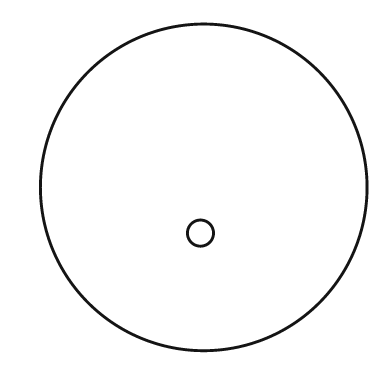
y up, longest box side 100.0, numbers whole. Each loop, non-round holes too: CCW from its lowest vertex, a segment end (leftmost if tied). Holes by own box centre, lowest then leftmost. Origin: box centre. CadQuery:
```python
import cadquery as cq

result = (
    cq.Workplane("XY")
    .moveTo(0.0, 0.0)
    .circle(50.0)
    .moveTo(-1.0, -14.0)
    .circle(4.0)
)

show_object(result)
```